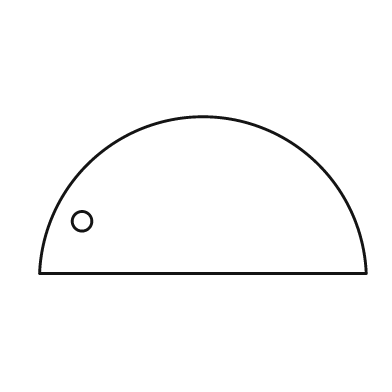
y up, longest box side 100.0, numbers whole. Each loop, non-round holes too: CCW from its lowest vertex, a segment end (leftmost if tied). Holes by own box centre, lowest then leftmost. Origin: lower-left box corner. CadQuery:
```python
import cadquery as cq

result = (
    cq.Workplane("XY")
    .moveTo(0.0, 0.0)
    .lineTo(100.0, 0.0)
    .threePointArc((50.0, 48.0), (0.0, 0.0))
    .close()
    .moveTo(13.0, 16.0)
    .circle(3.0)
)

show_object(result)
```